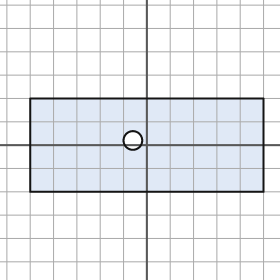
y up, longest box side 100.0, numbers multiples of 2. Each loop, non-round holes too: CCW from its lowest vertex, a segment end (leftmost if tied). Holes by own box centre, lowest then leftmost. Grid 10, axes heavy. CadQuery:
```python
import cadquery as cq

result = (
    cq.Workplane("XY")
    .moveTo(-50.0, -20.0)
    .lineTo(50.0, -20.0)
    .lineTo(50.0, 20.0)
    .lineTo(-50.0, 20.0)
    .close()
    .moveTo(-6.0, 2.0)
    .circle(4.0)
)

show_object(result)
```